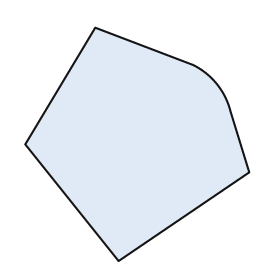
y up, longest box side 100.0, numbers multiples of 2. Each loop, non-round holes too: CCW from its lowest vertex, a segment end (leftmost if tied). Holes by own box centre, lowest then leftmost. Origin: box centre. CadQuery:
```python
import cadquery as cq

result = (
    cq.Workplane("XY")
    .moveTo(-8.0, -50.0)
    .lineTo(48.0, -12.0)
    .lineTo(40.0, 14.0)
    .threePointArc((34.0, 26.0), (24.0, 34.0))
    .lineTo(-18.0, 50.0)
    .lineTo(-48.0, 0.0)
    .close()
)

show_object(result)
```